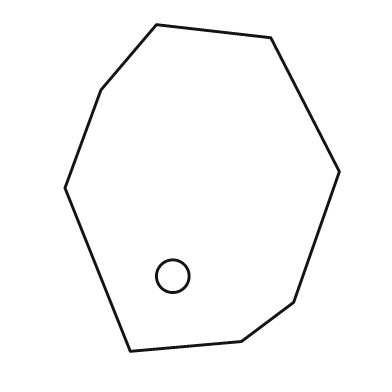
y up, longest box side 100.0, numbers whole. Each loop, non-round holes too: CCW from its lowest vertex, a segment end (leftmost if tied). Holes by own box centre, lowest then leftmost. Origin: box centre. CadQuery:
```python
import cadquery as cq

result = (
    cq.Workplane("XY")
    .moveTo(-22.0, -50.0)
    .lineTo(12.0, -47.0)
    .lineTo(28.0, -35.0)
    .lineTo(42.0, 5.0)
    .lineTo(21.0, 46.0)
    .lineTo(-14.0, 50.0)
    .lineTo(-31.0, 30.0)
    .lineTo(-42.0, 0.0)
    .close()
    .moveTo(-9.0, -27.0)
    .circle(5.0)
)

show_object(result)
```